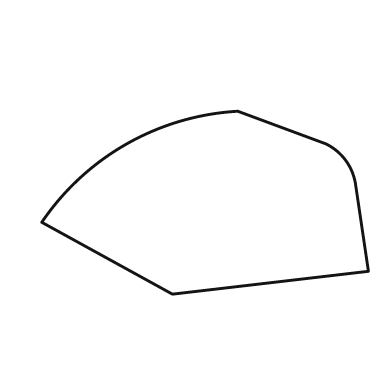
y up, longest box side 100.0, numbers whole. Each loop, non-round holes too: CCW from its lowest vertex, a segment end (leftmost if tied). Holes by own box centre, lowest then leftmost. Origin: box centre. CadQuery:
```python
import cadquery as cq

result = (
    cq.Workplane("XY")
    .moveTo(-10.0, -28.0)
    .lineTo(50.0, -21.0)
    .lineTo(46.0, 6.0)
    .threePointArc((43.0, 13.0), (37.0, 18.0))
    .lineTo(10.0, 28.0)
    .threePointArc((-24.0, 18.0), (-50.0, -6.0))
    .close()
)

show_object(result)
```